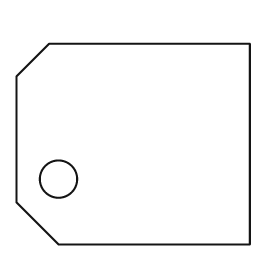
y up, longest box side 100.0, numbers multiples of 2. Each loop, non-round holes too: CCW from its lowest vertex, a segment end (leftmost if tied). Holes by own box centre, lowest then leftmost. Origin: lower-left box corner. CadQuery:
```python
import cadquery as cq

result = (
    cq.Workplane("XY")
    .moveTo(18.0, 0.0)
    .lineTo(100.0, 0.0)
    .lineTo(100.0, 86.0)
    .lineTo(14.0, 86.0)
    .lineTo(0.0, 72.0)
    .lineTo(0.0, 18.0)
    .close()
    .moveTo(18.0, 28.0)
    .circle(8.0)
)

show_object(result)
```